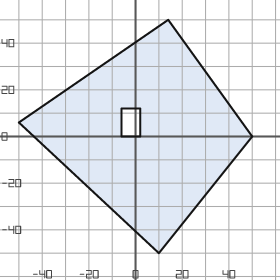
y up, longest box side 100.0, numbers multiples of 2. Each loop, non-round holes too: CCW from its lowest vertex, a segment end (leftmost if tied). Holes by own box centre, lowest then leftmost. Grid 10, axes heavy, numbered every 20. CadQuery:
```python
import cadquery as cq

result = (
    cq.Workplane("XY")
    .moveTo(10.0, -50.0)
    .lineTo(50.0, 0.0)
    .lineTo(14.0, 50.0)
    .lineTo(-50.0, 6.0)
    .close()
    .moveTo(-6.0, 0.0)
    .lineTo(2.0, 0.0)
    .lineTo(2.0, 12.0)
    .lineTo(-6.0, 12.0)
    .close()
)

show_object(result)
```